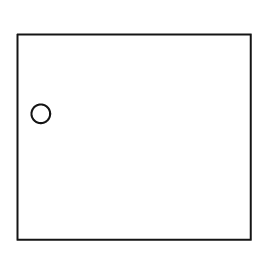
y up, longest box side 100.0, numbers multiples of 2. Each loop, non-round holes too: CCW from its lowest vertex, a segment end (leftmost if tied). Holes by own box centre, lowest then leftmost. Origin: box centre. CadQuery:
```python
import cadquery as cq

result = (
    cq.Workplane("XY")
    .moveTo(-50.0, -44.0)
    .lineTo(50.0, -44.0)
    .lineTo(50.0, 44.0)
    .lineTo(-50.0, 44.0)
    .close()
    .moveTo(-40.0, 10.0)
    .circle(4.0)
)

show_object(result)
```